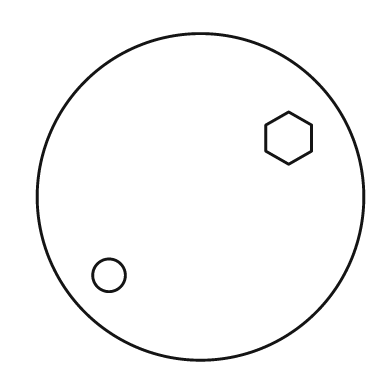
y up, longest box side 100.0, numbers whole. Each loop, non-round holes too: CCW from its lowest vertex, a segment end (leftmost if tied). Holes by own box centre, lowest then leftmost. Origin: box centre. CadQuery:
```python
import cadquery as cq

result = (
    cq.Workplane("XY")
    .moveTo(0.0, 0.0)
    .circle(50.0)
    .moveTo(-28.0, -24.0)
    .circle(5.0)
    .moveTo(27.0, 10.0)
    .lineTo(34.0, 14.0)
    .lineTo(34.0, 22.0)
    .lineTo(27.0, 26.0)
    .lineTo(20.0, 22.0)
    .lineTo(20.0, 14.0)
    .close()
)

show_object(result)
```